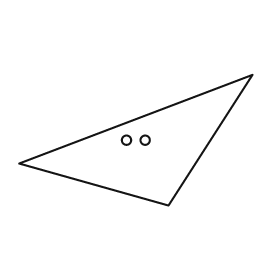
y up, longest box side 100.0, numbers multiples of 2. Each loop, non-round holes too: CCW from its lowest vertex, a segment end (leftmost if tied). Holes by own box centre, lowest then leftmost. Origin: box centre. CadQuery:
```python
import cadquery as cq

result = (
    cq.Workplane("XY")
    .moveTo(14.0, -28.0)
    .lineTo(50.0, 28.0)
    .lineTo(-50.0, -10.0)
    .close()
    .moveTo(-4.0, 0.0)
    .circle(2.0)
    .moveTo(4.0, 0.0)
    .circle(2.0)
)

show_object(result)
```